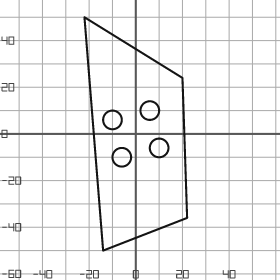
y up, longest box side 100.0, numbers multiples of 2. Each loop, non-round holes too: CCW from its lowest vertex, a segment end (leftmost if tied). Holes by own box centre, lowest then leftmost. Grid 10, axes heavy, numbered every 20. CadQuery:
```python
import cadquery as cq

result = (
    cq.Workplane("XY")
    .moveTo(-14.0, -50.0)
    .lineTo(22.0, -36.0)
    .lineTo(20.0, 24.0)
    .lineTo(-22.0, 50.0)
    .close()
    .moveTo(-6.0, -10.0)
    .circle(4.0)
    .moveTo(10.0, -6.0)
    .circle(4.0)
    .moveTo(-10.0, 6.0)
    .circle(4.0)
    .moveTo(6.0, 10.0)
    .circle(4.0)
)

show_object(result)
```